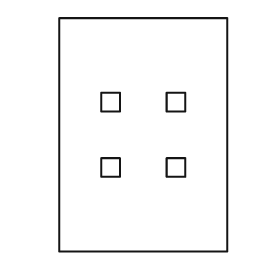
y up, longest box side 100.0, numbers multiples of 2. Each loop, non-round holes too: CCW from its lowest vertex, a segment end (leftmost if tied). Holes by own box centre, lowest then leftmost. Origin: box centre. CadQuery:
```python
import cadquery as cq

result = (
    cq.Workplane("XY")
    .moveTo(-36.0, -50.0)
    .lineTo(36.0, -50.0)
    .lineTo(36.0, 50.0)
    .lineTo(-36.0, 50.0)
    .close()
    .moveTo(-18.0, -18.0)
    .lineTo(-10.0, -18.0)
    .lineTo(-10.0, -10.0)
    .lineTo(-18.0, -10.0)
    .close()
    .moveTo(10.0, -18.0)
    .lineTo(18.0, -18.0)
    .lineTo(18.0, -10.0)
    .lineTo(10.0, -10.0)
    .close()
    .moveTo(-18.0, 10.0)
    .lineTo(-10.0, 10.0)
    .lineTo(-10.0, 18.0)
    .lineTo(-18.0, 18.0)
    .close()
    .moveTo(10.0, 10.0)
    .lineTo(18.0, 10.0)
    .lineTo(18.0, 18.0)
    .lineTo(10.0, 18.0)
    .close()
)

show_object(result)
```